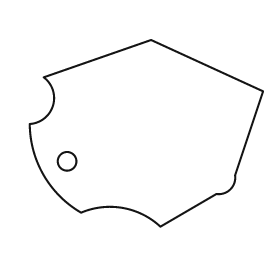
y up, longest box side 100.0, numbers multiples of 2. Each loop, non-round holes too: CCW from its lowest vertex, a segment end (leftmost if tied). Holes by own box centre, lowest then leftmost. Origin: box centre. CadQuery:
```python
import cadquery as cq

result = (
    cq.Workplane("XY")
    .moveTo(6.0, -40.0)
    .lineTo(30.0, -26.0)
    .threePointArc((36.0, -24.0), (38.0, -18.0))
    .lineTo(50.0, 18.0)
    .lineTo(2.0, 40.0)
    .lineTo(-44.0, 24.0)
    .threePointArc((-40.0, 12.0), (-50.0, 4.0))
    .threePointArc((-44.0, -18.0), (-28.0, -34.0))
    .threePointArc((-10.0, -32.0), (6.0, -40.0))
    .close()
    .moveTo(-34.0, -12.0)
    .circle(4.0)
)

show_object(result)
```